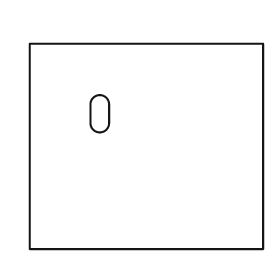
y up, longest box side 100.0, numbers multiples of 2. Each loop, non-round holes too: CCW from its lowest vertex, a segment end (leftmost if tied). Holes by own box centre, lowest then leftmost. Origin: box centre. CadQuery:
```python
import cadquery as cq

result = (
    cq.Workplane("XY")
    .moveTo(-50.0, -44.0)
    .lineTo(50.0, -44.0)
    .lineTo(50.0, 44.0)
    .lineTo(-50.0, 44.0)
    .close()
    .moveTo(-24.0, 10.0)
    .threePointArc((-20.0, 6.0), (-16.0, 10.0))
    .lineTo(-16.0, 18.0)
    .threePointArc((-20.0, 22.0), (-24.0, 18.0))
    .close()
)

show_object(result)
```